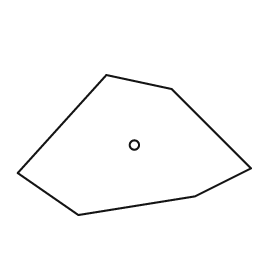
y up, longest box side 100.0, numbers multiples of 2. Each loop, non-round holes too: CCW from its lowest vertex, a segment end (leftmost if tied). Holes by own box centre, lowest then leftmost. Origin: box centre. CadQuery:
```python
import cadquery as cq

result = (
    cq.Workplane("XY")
    .moveTo(-24.0, -30.0)
    .lineTo(26.0, -22.0)
    .lineTo(50.0, -10.0)
    .lineTo(16.0, 24.0)
    .lineTo(-12.0, 30.0)
    .lineTo(-50.0, -12.0)
    .close()
    .moveTo(0.0, 0.0)
    .circle(2.0)
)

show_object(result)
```